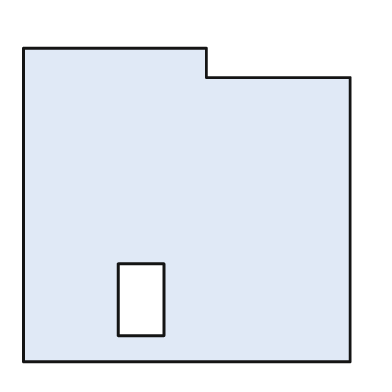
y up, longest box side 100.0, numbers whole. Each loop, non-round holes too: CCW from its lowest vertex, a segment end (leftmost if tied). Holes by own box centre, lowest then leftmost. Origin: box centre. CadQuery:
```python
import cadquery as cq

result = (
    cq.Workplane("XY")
    .moveTo(-50.0, -48.0)
    .lineTo(50.0, -48.0)
    .lineTo(50.0, 39.0)
    .lineTo(6.0, 39.0)
    .lineTo(6.0, 48.0)
    .lineTo(-50.0, 48.0)
    .close()
    .moveTo(-21.0, -40.0)
    .lineTo(-7.0, -40.0)
    .lineTo(-7.0, -18.0)
    .lineTo(-21.0, -18.0)
    .close()
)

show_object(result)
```